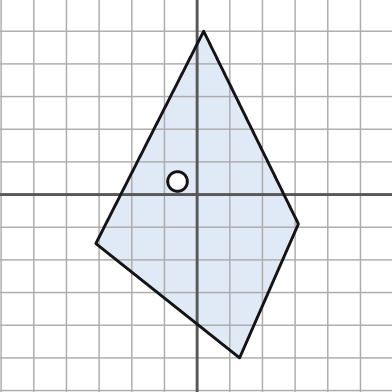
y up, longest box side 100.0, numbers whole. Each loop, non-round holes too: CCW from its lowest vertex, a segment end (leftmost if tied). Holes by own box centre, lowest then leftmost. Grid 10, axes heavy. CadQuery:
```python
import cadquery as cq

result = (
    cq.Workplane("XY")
    .moveTo(13.0, -50.0)
    .lineTo(31.0, -9.0)
    .lineTo(2.0, 50.0)
    .lineTo(-31.0, -15.0)
    .close()
    .moveTo(-6.0, 4.0)
    .circle(3.0)
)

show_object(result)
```